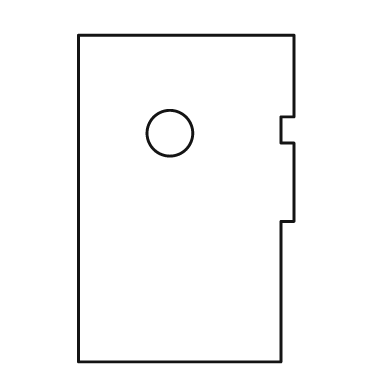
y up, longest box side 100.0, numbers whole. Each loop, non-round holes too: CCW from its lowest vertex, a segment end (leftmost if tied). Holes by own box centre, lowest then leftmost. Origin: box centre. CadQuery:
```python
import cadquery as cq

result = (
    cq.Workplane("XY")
    .moveTo(-33.0, -50.0)
    .lineTo(29.0, -50.0)
    .lineTo(29.0, -7.0)
    .lineTo(33.0, -7.0)
    .lineTo(33.0, 17.0)
    .lineTo(29.0, 17.0)
    .lineTo(29.0, 25.0)
    .lineTo(33.0, 25.0)
    .lineTo(33.0, 50.0)
    .lineTo(-33.0, 50.0)
    .close()
    .moveTo(-5.0, 20.0)
    .circle(7.0)
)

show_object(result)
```